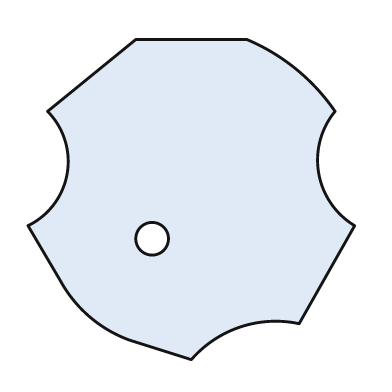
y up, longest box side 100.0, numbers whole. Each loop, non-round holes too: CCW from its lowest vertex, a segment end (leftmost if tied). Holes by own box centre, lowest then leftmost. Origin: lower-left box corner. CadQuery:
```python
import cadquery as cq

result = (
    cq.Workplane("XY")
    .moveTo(50.0, 0.0)
    .threePointArc((65.0, 10.0), (83.0, 11.0))
    .lineTo(100.0, 41.0)
    .threePointArc((89.0, 57.0), (94.0, 76.0))
    .threePointArc((82.0, 89.0), (67.0, 98.0))
    .lineTo(33.0, 98.0)
    .lineTo(6.0, 76.0)
    .threePointArc((12.0, 57.0), (0.0, 41.0))
    .lineTo(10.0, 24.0)
    .threePointArc((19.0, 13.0), (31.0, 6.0))
    .close()
    .moveTo(38.0, 37.0)
    .circle(5.0)
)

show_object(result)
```